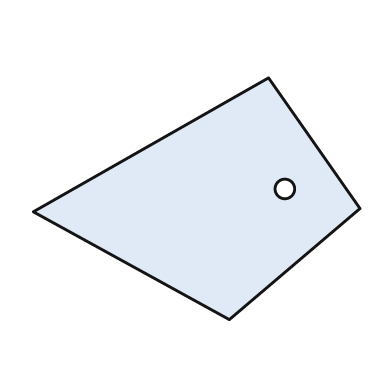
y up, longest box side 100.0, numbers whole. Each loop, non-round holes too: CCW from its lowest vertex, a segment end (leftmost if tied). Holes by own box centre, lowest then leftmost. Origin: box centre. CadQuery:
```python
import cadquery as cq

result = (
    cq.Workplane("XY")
    .moveTo(10.0, -37.0)
    .lineTo(50.0, -3.0)
    .lineTo(22.0, 37.0)
    .lineTo(-50.0, -4.0)
    .close()
    .moveTo(27.0, 3.0)
    .circle(3.0)
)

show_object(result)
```